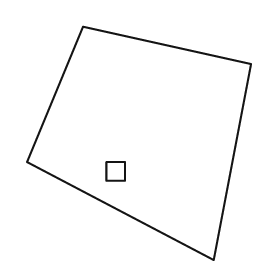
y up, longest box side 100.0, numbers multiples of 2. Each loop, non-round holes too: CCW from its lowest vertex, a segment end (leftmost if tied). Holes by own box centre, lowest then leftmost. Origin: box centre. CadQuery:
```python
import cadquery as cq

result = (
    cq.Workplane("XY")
    .moveTo(32.0, -50.0)
    .lineTo(48.0, 34.0)
    .lineTo(-24.0, 50.0)
    .lineTo(-48.0, -8.0)
    .close()
    .moveTo(-14.0, -16.0)
    .lineTo(-6.0, -16.0)
    .lineTo(-6.0, -8.0)
    .lineTo(-14.0, -8.0)
    .close()
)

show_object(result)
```